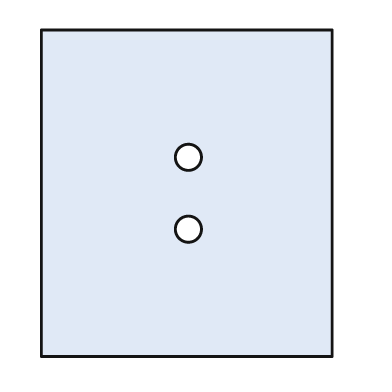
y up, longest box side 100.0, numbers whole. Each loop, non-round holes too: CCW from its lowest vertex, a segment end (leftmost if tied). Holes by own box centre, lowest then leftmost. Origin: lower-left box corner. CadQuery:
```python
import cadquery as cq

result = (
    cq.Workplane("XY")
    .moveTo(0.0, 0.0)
    .lineTo(89.0, 0.0)
    .lineTo(89.0, 100.0)
    .lineTo(0.0, 100.0)
    .close()
    .moveTo(45.0, 39.0)
    .circle(4.0)
    .moveTo(45.0, 61.0)
    .circle(4.0)
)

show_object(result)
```